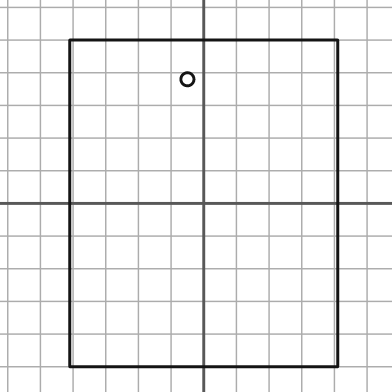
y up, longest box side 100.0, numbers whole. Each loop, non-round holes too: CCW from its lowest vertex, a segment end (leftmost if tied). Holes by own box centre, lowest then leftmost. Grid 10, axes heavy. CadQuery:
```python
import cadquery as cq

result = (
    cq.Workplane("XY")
    .moveTo(-41.0, -50.0)
    .lineTo(41.0, -50.0)
    .lineTo(41.0, 50.0)
    .lineTo(-41.0, 50.0)
    .close()
    .moveTo(-5.0, 38.0)
    .circle(2.0)
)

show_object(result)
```